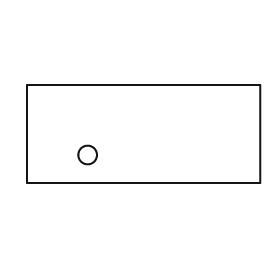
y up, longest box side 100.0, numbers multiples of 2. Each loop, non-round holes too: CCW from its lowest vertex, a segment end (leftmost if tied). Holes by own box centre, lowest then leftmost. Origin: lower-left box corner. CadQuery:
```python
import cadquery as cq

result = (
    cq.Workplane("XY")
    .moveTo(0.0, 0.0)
    .lineTo(100.0, 0.0)
    .lineTo(100.0, 42.0)
    .lineTo(0.0, 42.0)
    .close()
    .moveTo(26.0, 12.0)
    .circle(4.0)
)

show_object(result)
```